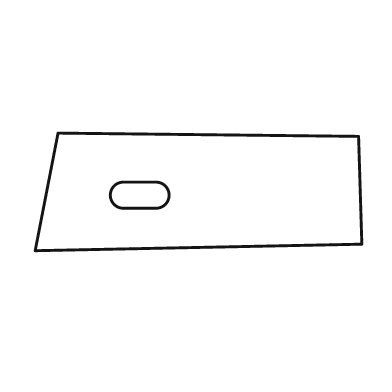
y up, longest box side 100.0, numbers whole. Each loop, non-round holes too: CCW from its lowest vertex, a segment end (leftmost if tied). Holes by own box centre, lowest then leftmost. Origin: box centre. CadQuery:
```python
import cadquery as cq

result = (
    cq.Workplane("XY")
    .moveTo(-50.0, -18.0)
    .lineTo(50.0, -16.0)
    .lineTo(49.0, 17.0)
    .lineTo(-43.0, 18.0)
    .close()
    .moveTo(-23.0, -5.0)
    .lineTo(-13.0, -5.0)
    .threePointArc((-9.0, -1.0), (-13.0, 3.0))
    .lineTo(-23.0, 3.0)
    .threePointArc((-27.0, -1.0), (-23.0, -5.0))
    .close()
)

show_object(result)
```